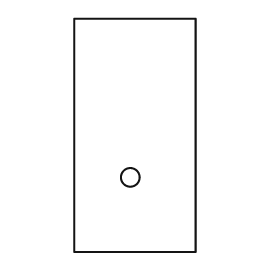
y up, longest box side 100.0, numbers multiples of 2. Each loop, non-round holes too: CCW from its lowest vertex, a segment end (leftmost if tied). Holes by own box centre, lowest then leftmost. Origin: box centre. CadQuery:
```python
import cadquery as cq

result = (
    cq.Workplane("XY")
    .moveTo(-26.0, -50.0)
    .lineTo(26.0, -50.0)
    .lineTo(26.0, 50.0)
    .lineTo(-26.0, 50.0)
    .close()
    .moveTo(-2.0, -18.0)
    .circle(4.0)
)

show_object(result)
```